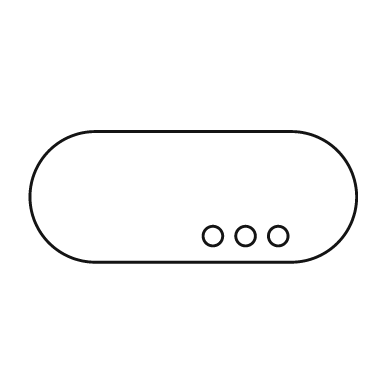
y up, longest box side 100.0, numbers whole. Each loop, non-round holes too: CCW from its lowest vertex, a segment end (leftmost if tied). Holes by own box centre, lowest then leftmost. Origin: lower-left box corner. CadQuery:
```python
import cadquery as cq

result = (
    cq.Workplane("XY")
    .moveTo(20.0, 0.0)
    .lineTo(80.0, 0.0)
    .threePointArc((100.0, 20.0), (80.0, 40.0))
    .lineTo(20.0, 40.0)
    .threePointArc((0.0, 20.0), (20.0, 0.0))
    .close()
    .moveTo(56.0, 8.0)
    .circle(3.0)
    .moveTo(66.0, 8.0)
    .circle(3.0)
    .moveTo(76.0, 8.0)
    .circle(3.0)
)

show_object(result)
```